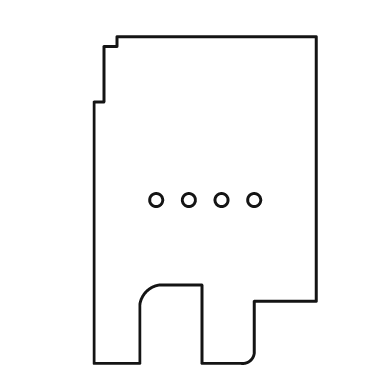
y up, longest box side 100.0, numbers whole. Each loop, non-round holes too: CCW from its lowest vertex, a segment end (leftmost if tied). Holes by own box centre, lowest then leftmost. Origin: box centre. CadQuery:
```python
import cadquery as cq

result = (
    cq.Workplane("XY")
    .moveTo(-34.0, -50.0)
    .lineTo(-20.0, -50.0)
    .lineTo(-20.0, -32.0)
    .threePointArc((-18.0, -28.0), (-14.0, -26.0))
    .lineTo(-1.0, -26.0)
    .lineTo(-1.0, -50.0)
    .lineTo(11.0, -50.0)
    .threePointArc((14.0, -49.0), (15.0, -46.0))
    .lineTo(15.0, -31.0)
    .lineTo(34.0, -31.0)
    .lineTo(34.0, 50.0)
    .lineTo(-27.0, 50.0)
    .lineTo(-27.0, 47.0)
    .lineTo(-31.0, 47.0)
    .lineTo(-31.0, 30.0)
    .lineTo(-34.0, 30.0)
    .close()
    .moveTo(-15.0, 0.0)
    .circle(2.0)
    .moveTo(-5.0, 0.0)
    .circle(2.0)
    .moveTo(5.0, 0.0)
    .circle(2.0)
    .moveTo(15.0, 0.0)
    .circle(2.0)
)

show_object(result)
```